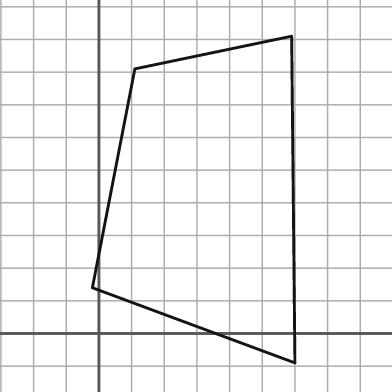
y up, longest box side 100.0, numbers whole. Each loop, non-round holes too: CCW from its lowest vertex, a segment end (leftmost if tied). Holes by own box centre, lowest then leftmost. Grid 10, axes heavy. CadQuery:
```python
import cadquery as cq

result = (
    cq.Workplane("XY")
    .moveTo(60.0, -9.0)
    .lineTo(59.0, 91.0)
    .lineTo(11.0, 81.0)
    .lineTo(-2.0, 14.0)
    .close()
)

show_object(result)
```